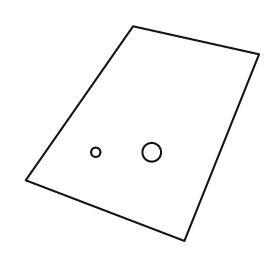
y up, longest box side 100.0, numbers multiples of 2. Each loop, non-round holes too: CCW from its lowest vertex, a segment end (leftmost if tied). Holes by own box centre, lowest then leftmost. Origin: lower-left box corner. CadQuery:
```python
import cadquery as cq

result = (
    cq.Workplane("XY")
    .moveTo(68.0, 0.0)
    .lineTo(100.0, 80.0)
    .lineTo(46.0, 92.0)
    .lineTo(0.0, 26.0)
    .close()
    .moveTo(30.0, 38.0)
    .circle(2.0)
    .moveTo(54.0, 38.0)
    .circle(4.0)
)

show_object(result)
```